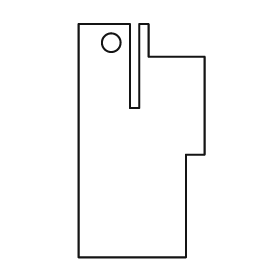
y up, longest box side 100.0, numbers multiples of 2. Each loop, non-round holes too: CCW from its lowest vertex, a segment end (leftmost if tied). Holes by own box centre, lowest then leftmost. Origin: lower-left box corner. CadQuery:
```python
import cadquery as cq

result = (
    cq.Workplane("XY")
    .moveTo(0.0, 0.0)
    .lineTo(46.0, 0.0)
    .lineTo(46.0, 44.0)
    .lineTo(54.0, 44.0)
    .lineTo(54.0, 86.0)
    .lineTo(30.0, 86.0)
    .lineTo(30.0, 100.0)
    .lineTo(26.0, 100.0)
    .lineTo(26.0, 64.0)
    .lineTo(22.0, 64.0)
    .lineTo(22.0, 100.0)
    .lineTo(0.0, 100.0)
    .close()
    .moveTo(14.0, 92.0)
    .circle(4.0)
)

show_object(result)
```